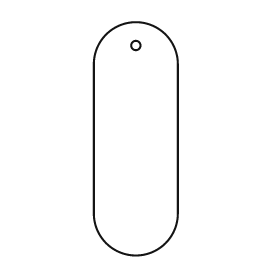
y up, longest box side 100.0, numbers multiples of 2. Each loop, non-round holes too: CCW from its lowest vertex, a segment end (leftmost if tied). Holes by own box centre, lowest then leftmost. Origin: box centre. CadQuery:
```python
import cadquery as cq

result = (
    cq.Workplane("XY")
    .moveTo(-18.0, -32.0)
    .threePointArc((0.0, -50.0), (18.0, -32.0))
    .lineTo(18.0, 32.0)
    .threePointArc((0.0, 50.0), (-18.0, 32.0))
    .close()
    .moveTo(0.0, 40.0)
    .circle(2.0)
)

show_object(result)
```